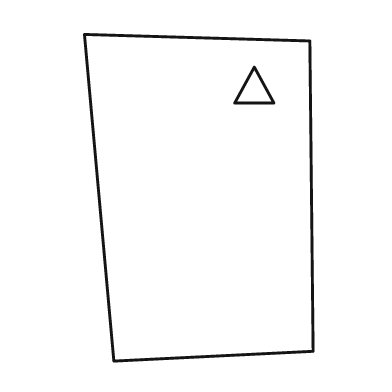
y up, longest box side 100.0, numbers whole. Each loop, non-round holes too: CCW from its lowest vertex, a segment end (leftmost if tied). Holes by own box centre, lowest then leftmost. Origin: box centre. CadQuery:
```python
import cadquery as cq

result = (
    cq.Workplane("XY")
    .moveTo(-26.0, -50.0)
    .lineTo(35.0, -47.0)
    .lineTo(34.0, 48.0)
    .lineTo(-35.0, 50.0)
    .close()
    .moveTo(11.0, 29.0)
    .lineTo(23.0, 29.0)
    .lineTo(17.0, 40.0)
    .close()
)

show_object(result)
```